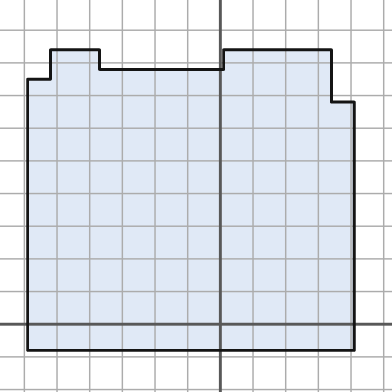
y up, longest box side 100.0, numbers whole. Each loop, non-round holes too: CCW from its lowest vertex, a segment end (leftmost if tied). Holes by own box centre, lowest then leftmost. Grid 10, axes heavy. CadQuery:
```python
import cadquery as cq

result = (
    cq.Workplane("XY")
    .moveTo(-59.0, -8.0)
    .lineTo(41.0, -8.0)
    .lineTo(41.0, 68.0)
    .lineTo(34.0, 68.0)
    .lineTo(34.0, 84.0)
    .lineTo(1.0, 84.0)
    .lineTo(1.0, 78.0)
    .lineTo(-37.0, 78.0)
    .lineTo(-37.0, 84.0)
    .lineTo(-52.0, 84.0)
    .lineTo(-52.0, 75.0)
    .lineTo(-59.0, 75.0)
    .close()
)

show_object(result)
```